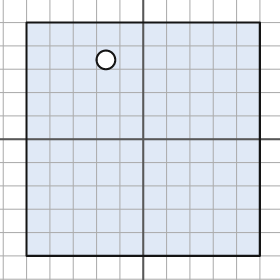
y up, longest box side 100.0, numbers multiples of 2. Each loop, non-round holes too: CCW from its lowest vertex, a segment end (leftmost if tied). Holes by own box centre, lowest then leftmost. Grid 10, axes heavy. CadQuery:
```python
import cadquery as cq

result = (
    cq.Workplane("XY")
    .moveTo(-50.0, -50.0)
    .lineTo(50.0, -50.0)
    .lineTo(50.0, 50.0)
    .lineTo(-50.0, 50.0)
    .close()
    .moveTo(-16.0, 34.0)
    .circle(4.0)
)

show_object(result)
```